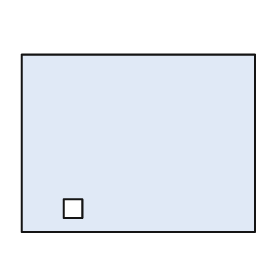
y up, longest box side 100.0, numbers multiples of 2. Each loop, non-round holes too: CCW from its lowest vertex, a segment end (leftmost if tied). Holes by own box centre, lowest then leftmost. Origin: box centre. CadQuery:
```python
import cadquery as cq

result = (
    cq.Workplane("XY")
    .moveTo(-50.0, -38.0)
    .lineTo(50.0, -38.0)
    .lineTo(50.0, 38.0)
    .lineTo(-50.0, 38.0)
    .close()
    .moveTo(-32.0, -32.0)
    .lineTo(-24.0, -32.0)
    .lineTo(-24.0, -24.0)
    .lineTo(-32.0, -24.0)
    .close()
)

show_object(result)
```